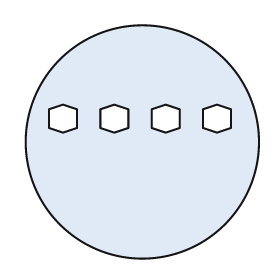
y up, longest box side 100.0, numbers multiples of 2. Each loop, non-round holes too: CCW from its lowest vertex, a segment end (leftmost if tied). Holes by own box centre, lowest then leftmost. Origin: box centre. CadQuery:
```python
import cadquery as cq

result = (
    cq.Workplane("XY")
    .moveTo(0.0, 0.0)
    .circle(50.0)
    .moveTo(-34.0, 4.0)
    .lineTo(-28.0, 6.0)
    .lineTo(-28.0, 14.0)
    .lineTo(-34.0, 16.0)
    .lineTo(-40.0, 14.0)
    .lineTo(-40.0, 6.0)
    .close()
    .moveTo(-12.0, 4.0)
    .lineTo(-6.0, 6.0)
    .lineTo(-6.0, 14.0)
    .lineTo(-12.0, 16.0)
    .lineTo(-18.0, 14.0)
    .lineTo(-18.0, 6.0)
    .close()
    .moveTo(10.0, 4.0)
    .lineTo(16.0, 6.0)
    .lineTo(16.0, 14.0)
    .lineTo(10.0, 16.0)
    .lineTo(4.0, 14.0)
    .lineTo(4.0, 6.0)
    .close()
    .moveTo(32.0, 4.0)
    .lineTo(38.0, 6.0)
    .lineTo(38.0, 14.0)
    .lineTo(32.0, 16.0)
    .lineTo(26.0, 14.0)
    .lineTo(26.0, 6.0)
    .close()
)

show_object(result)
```